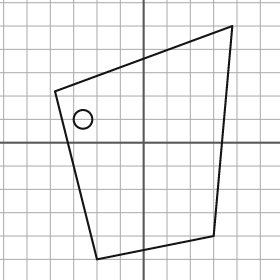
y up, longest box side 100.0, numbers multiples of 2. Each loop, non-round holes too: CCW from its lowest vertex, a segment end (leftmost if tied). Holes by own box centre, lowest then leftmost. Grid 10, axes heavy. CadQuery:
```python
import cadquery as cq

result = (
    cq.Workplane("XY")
    .moveTo(-20.0, -50.0)
    .lineTo(30.0, -40.0)
    .lineTo(38.0, 50.0)
    .lineTo(-38.0, 22.0)
    .close()
    .moveTo(-26.0, 10.0)
    .circle(4.0)
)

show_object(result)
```